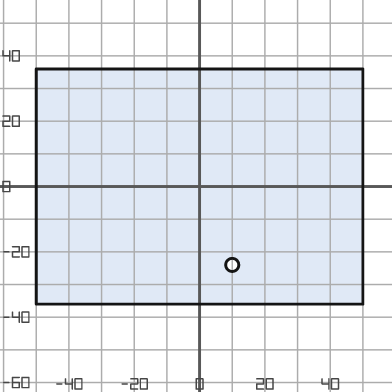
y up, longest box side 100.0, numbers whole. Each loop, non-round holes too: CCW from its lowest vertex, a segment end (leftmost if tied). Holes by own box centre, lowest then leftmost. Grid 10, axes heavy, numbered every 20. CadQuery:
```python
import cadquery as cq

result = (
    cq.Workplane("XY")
    .moveTo(-50.0, -36.0)
    .lineTo(50.0, -36.0)
    .lineTo(50.0, 36.0)
    .lineTo(-50.0, 36.0)
    .close()
    .moveTo(10.0, -24.0)
    .circle(2.0)
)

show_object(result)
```